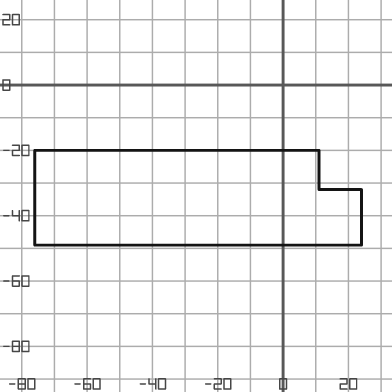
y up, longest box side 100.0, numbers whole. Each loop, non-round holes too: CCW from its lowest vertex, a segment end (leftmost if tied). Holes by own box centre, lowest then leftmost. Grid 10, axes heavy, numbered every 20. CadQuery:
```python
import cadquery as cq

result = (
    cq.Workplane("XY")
    .moveTo(-76.0, -49.0)
    .lineTo(24.0, -49.0)
    .lineTo(24.0, -32.0)
    .lineTo(11.0, -32.0)
    .lineTo(11.0, -20.0)
    .lineTo(-76.0, -20.0)
    .close()
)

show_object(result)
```